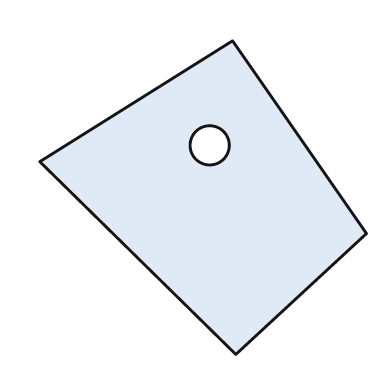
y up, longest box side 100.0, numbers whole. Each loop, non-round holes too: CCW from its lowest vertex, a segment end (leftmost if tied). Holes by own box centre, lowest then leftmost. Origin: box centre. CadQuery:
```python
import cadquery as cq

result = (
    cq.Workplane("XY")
    .moveTo(10.0, -48.0)
    .lineTo(50.0, -11.0)
    .lineTo(9.0, 48.0)
    .lineTo(-50.0, 11.0)
    .close()
    .moveTo(2.0, 16.0)
    .circle(6.0)
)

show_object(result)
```